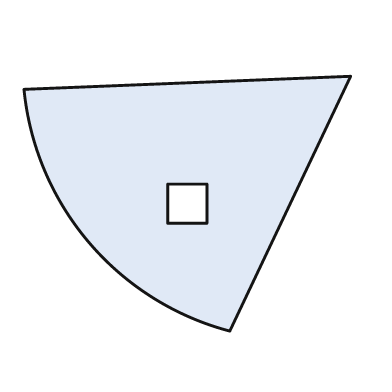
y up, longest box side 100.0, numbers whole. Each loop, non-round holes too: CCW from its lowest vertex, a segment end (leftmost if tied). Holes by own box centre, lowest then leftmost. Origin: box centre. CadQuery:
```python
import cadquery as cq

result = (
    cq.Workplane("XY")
    .moveTo(13.0, -39.0)
    .lineTo(50.0, 39.0)
    .lineTo(-50.0, 35.0)
    .threePointArc((-30.0, -12.0), (13.0, -39.0))
    .close()
    .moveTo(-6.0, -6.0)
    .lineTo(6.0, -6.0)
    .lineTo(6.0, 6.0)
    .lineTo(-6.0, 6.0)
    .close()
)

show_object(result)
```